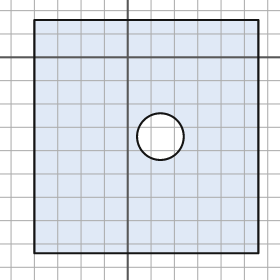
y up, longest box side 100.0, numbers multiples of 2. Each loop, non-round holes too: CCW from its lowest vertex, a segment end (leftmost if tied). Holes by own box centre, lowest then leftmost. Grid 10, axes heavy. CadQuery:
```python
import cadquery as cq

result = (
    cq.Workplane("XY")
    .moveTo(-40.0, -84.0)
    .lineTo(56.0, -84.0)
    .lineTo(56.0, 16.0)
    .lineTo(-40.0, 16.0)
    .close()
    .moveTo(14.0, -34.0)
    .circle(10.0)
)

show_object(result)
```